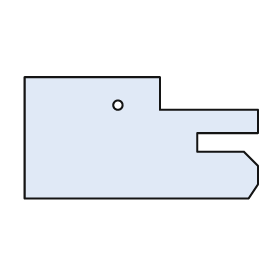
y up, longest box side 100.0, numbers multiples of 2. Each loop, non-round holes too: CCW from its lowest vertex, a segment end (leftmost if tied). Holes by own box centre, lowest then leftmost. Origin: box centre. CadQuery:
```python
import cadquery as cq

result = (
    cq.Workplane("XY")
    .moveTo(-50.0, -26.0)
    .lineTo(46.0, -26.0)
    .lineTo(50.0, -20.0)
    .lineTo(50.0, -12.0)
    .lineTo(44.0, -6.0)
    .lineTo(24.0, -6.0)
    .lineTo(24.0, 2.0)
    .lineTo(50.0, 2.0)
    .lineTo(50.0, 12.0)
    .lineTo(8.0, 12.0)
    .lineTo(8.0, 26.0)
    .lineTo(-50.0, 26.0)
    .close()
    .moveTo(-10.0, 14.0)
    .circle(2.0)
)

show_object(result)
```